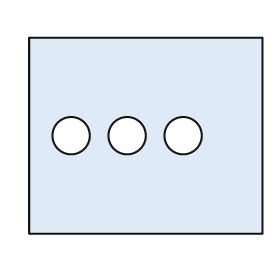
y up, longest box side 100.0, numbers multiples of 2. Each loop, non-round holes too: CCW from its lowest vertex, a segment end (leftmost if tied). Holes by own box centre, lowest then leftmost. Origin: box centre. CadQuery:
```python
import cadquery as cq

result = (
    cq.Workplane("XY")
    .moveTo(-50.0, -42.0)
    .lineTo(50.0, -42.0)
    .lineTo(50.0, 42.0)
    .lineTo(-50.0, 42.0)
    .close()
    .moveTo(-32.0, 0.0)
    .circle(8.0)
    .moveTo(-8.0, 0.0)
    .circle(8.0)
    .moveTo(16.0, 0.0)
    .circle(8.0)
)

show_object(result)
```